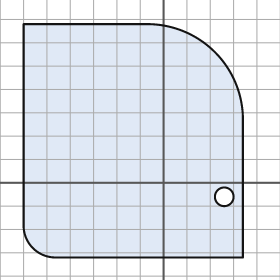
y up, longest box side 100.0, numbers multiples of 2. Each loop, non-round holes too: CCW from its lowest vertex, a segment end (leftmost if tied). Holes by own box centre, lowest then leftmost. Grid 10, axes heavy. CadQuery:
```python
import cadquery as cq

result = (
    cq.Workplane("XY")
    .moveTo(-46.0, -32.0)
    .lineTo(34.0, -32.0)
    .lineTo(34.0, 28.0)
    .threePointArc((22.0, 56.0), (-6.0, 68.0))
    .lineTo(-60.0, 68.0)
    .lineTo(-60.0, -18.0)
    .threePointArc((-56.0, -28.0), (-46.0, -32.0))
    .close()
    .moveTo(26.0, -6.0)
    .circle(4.0)
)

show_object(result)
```